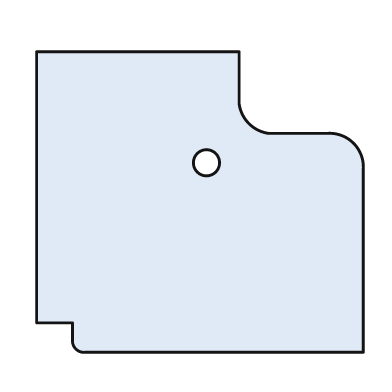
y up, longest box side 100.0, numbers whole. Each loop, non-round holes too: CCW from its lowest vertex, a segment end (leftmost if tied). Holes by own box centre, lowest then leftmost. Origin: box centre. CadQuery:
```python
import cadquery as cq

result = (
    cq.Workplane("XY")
    .moveTo(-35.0, -46.0)
    .lineTo(50.0, -46.0)
    .lineTo(50.0, 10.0)
    .threePointArc((47.0, 18.0), (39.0, 21.0))
    .lineTo(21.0, 21.0)
    .threePointArc((15.0, 24.0), (12.0, 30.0))
    .lineTo(12.0, 46.0)
    .lineTo(-50.0, 46.0)
    .lineTo(-50.0, -37.0)
    .lineTo(-39.0, -37.0)
    .lineTo(-39.0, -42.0)
    .threePointArc((-38.0, -45.0), (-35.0, -46.0))
    .close()
    .moveTo(2.0, 12.0)
    .circle(4.0)
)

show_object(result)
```